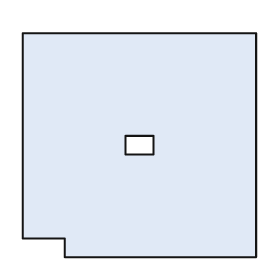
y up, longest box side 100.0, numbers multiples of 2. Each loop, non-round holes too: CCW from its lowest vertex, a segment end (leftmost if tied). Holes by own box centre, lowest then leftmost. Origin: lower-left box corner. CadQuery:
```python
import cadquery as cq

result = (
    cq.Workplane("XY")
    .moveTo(18.0, 0.0)
    .lineTo(100.0, 0.0)
    .lineTo(100.0, 96.0)
    .lineTo(0.0, 96.0)
    .lineTo(0.0, 8.0)
    .lineTo(18.0, 8.0)
    .close()
    .moveTo(44.0, 44.0)
    .lineTo(56.0, 44.0)
    .lineTo(56.0, 52.0)
    .lineTo(44.0, 52.0)
    .close()
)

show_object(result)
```